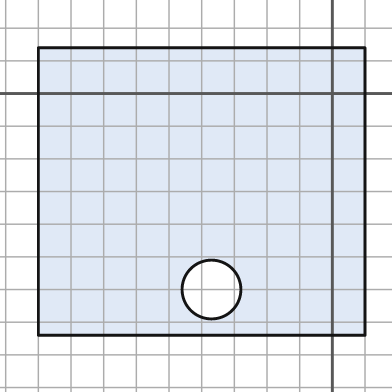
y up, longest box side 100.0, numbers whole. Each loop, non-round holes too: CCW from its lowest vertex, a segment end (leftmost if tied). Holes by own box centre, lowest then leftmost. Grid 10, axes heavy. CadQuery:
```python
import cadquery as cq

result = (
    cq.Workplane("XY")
    .moveTo(-90.0, -74.0)
    .lineTo(10.0, -74.0)
    .lineTo(10.0, 14.0)
    .lineTo(-90.0, 14.0)
    .close()
    .moveTo(-37.0, -60.0)
    .circle(9.0)
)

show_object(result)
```